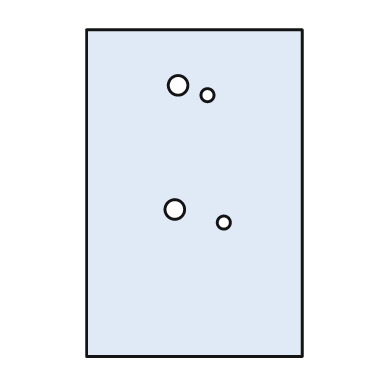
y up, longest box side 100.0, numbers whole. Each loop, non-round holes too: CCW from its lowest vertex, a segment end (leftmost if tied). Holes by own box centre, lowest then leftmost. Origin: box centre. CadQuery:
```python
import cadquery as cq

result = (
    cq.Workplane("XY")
    .moveTo(-33.0, -50.0)
    .lineTo(33.0, -50.0)
    .lineTo(33.0, 50.0)
    .lineTo(-33.0, 50.0)
    .close()
    .moveTo(9.0, -9.0)
    .circle(2.0)
    .moveTo(-6.0, -5.0)
    .circle(3.0)
    .moveTo(4.0, 30.0)
    .circle(2.0)
    .moveTo(-5.0, 33.0)
    .circle(3.0)
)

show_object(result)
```